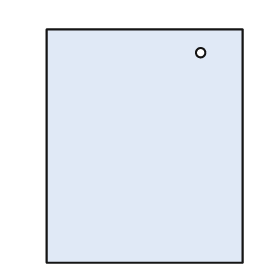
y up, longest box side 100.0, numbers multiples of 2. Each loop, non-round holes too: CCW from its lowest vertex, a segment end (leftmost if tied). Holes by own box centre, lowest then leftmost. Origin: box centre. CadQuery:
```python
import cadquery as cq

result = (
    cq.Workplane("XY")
    .moveTo(-42.0, -50.0)
    .lineTo(42.0, -50.0)
    .lineTo(42.0, 50.0)
    .lineTo(-42.0, 50.0)
    .close()
    .moveTo(24.0, 40.0)
    .circle(2.0)
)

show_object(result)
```